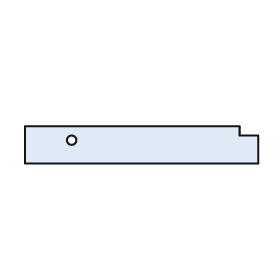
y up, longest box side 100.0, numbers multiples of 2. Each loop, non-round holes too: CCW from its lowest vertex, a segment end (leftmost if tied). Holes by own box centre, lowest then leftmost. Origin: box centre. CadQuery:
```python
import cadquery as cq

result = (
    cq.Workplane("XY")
    .moveTo(-50.0, -8.0)
    .lineTo(50.0, -8.0)
    .lineTo(50.0, 4.0)
    .lineTo(42.0, 4.0)
    .lineTo(42.0, 8.0)
    .lineTo(-50.0, 8.0)
    .close()
    .moveTo(-30.0, 2.0)
    .circle(2.0)
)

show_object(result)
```